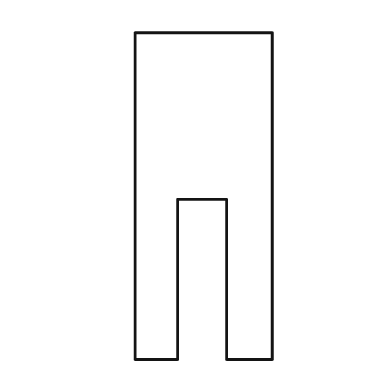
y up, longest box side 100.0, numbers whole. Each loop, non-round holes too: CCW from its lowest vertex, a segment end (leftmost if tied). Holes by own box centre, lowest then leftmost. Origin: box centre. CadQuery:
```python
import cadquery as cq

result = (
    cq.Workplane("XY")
    .moveTo(-21.0, -50.0)
    .lineTo(-8.0, -50.0)
    .lineTo(-8.0, -1.0)
    .lineTo(7.0, -1.0)
    .lineTo(7.0, -50.0)
    .lineTo(21.0, -50.0)
    .lineTo(21.0, 50.0)
    .lineTo(-21.0, 50.0)
    .close()
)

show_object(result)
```